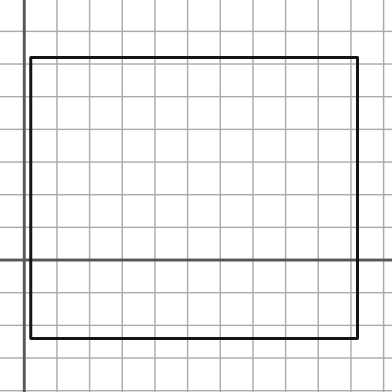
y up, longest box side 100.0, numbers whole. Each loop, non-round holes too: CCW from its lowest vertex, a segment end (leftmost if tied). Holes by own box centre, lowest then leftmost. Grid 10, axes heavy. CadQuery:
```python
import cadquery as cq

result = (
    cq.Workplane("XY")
    .moveTo(2.0, -24.0)
    .lineTo(102.0, -24.0)
    .lineTo(102.0, 62.0)
    .lineTo(2.0, 62.0)
    .close()
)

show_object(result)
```